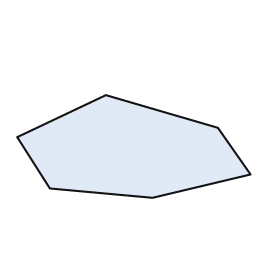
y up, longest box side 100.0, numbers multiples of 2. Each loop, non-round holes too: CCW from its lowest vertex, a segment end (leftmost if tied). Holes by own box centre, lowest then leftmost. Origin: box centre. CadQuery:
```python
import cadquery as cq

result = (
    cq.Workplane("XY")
    .moveTo(8.0, -22.0)
    .lineTo(50.0, -12.0)
    .lineTo(36.0, 8.0)
    .lineTo(-12.0, 22.0)
    .lineTo(-50.0, 4.0)
    .lineTo(-36.0, -18.0)
    .close()
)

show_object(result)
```